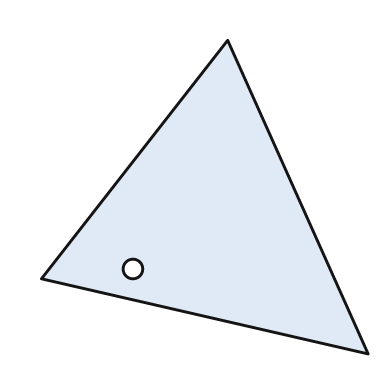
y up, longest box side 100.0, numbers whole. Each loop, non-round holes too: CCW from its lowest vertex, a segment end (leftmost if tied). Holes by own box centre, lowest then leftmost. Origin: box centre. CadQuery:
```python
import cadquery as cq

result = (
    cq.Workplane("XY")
    .moveTo(50.0, -48.0)
    .lineTo(7.0, 48.0)
    .lineTo(-50.0, -25.0)
    .close()
    .moveTo(-22.0, -22.0)
    .circle(3.0)
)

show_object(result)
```